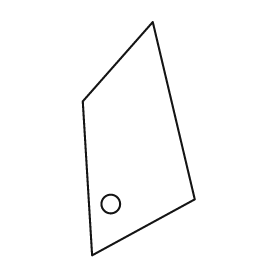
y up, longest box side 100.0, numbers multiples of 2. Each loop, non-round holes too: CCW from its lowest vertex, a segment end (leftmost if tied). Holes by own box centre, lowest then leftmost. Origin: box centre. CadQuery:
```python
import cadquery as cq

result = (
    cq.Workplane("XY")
    .moveTo(-20.0, -50.0)
    .lineTo(24.0, -26.0)
    .lineTo(6.0, 50.0)
    .lineTo(-24.0, 16.0)
    .close()
    .moveTo(-12.0, -28.0)
    .circle(4.0)
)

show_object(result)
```